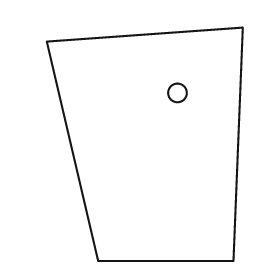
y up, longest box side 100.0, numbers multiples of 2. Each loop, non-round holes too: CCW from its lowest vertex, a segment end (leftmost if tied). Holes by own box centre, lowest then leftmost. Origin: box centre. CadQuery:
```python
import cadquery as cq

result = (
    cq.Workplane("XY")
    .moveTo(-20.0, -50.0)
    .lineTo(38.0, -50.0)
    .lineTo(42.0, 50.0)
    .lineTo(-42.0, 44.0)
    .close()
    .moveTo(14.0, 22.0)
    .circle(4.0)
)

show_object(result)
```